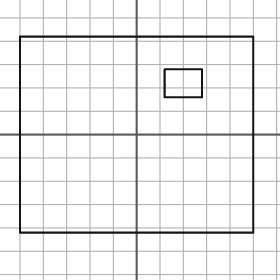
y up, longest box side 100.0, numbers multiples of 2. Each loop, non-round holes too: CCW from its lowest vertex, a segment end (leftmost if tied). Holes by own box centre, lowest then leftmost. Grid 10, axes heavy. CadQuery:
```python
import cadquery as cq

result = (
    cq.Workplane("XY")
    .moveTo(-50.0, -42.0)
    .lineTo(50.0, -42.0)
    .lineTo(50.0, 42.0)
    .lineTo(-50.0, 42.0)
    .close()
    .moveTo(12.0, 16.0)
    .lineTo(28.0, 16.0)
    .lineTo(28.0, 28.0)
    .lineTo(12.0, 28.0)
    .close()
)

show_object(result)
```